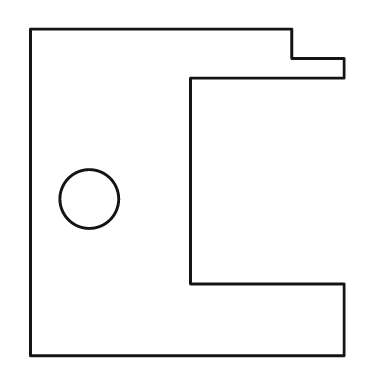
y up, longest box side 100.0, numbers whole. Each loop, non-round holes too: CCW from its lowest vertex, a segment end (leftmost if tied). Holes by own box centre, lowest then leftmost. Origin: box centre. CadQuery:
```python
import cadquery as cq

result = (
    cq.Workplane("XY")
    .moveTo(-48.0, -50.0)
    .lineTo(48.0, -50.0)
    .lineTo(48.0, -28.0)
    .lineTo(1.0, -28.0)
    .lineTo(1.0, 35.0)
    .lineTo(48.0, 35.0)
    .lineTo(48.0, 41.0)
    .lineTo(32.0, 41.0)
    .lineTo(32.0, 50.0)
    .lineTo(-48.0, 50.0)
    .close()
    .moveTo(-30.0, -2.0)
    .circle(9.0)
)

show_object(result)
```